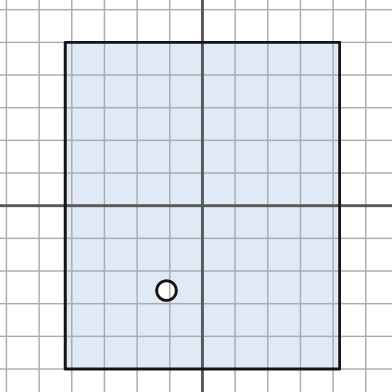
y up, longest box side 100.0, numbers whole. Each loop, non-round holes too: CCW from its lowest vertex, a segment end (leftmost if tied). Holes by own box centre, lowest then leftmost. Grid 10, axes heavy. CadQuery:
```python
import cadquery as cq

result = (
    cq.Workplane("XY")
    .moveTo(-42.0, -50.0)
    .lineTo(42.0, -50.0)
    .lineTo(42.0, 50.0)
    .lineTo(-42.0, 50.0)
    .close()
    .moveTo(-11.0, -26.0)
    .circle(3.0)
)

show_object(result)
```